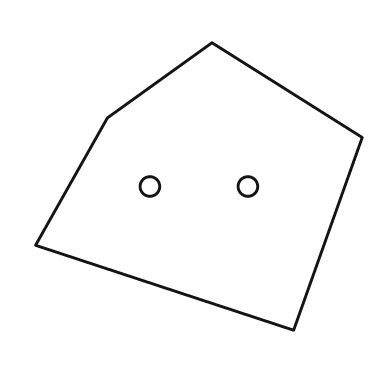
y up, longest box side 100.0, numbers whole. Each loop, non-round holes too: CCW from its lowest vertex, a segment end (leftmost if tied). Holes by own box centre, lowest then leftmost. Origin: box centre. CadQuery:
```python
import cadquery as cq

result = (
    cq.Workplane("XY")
    .moveTo(29.0, -44.0)
    .lineTo(50.0, 15.0)
    .lineTo(4.0, 44.0)
    .lineTo(-28.0, 21.0)
    .lineTo(-50.0, -18.0)
    .close()
    .moveTo(-15.0, 0.0)
    .circle(3.0)
    .moveTo(15.0, 0.0)
    .circle(3.0)
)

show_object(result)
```